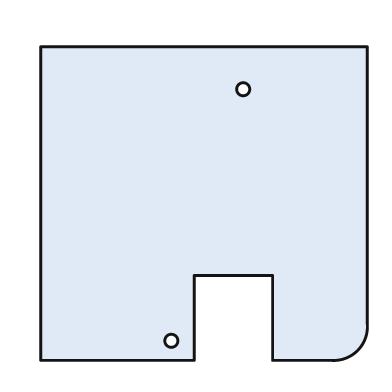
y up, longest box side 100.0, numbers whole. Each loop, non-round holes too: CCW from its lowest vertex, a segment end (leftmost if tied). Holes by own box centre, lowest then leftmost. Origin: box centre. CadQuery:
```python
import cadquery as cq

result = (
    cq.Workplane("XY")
    .moveTo(-50.0, -48.0)
    .lineTo(-3.0, -48.0)
    .lineTo(-3.0, -22.0)
    .lineTo(21.0, -22.0)
    .lineTo(21.0, -48.0)
    .lineTo(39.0, -48.0)
    .threePointArc((47.0, -45.0), (50.0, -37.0))
    .lineTo(50.0, 48.0)
    .lineTo(-50.0, 48.0)
    .close()
    .moveTo(-10.0, -42.0)
    .circle(2.0)
    .moveTo(12.0, 35.0)
    .circle(2.0)
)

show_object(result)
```